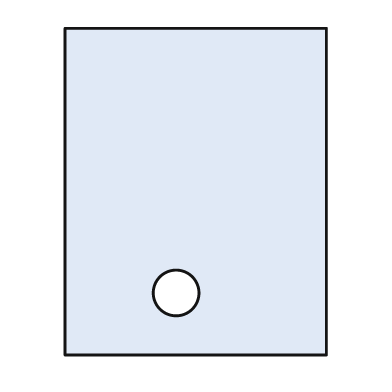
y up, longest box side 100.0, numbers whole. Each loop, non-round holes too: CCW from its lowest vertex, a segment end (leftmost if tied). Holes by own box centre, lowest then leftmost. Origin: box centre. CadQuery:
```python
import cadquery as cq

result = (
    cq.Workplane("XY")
    .moveTo(-40.0, -50.0)
    .lineTo(40.0, -50.0)
    .lineTo(40.0, 50.0)
    .lineTo(-40.0, 50.0)
    .close()
    .moveTo(-6.0, -31.0)
    .circle(7.0)
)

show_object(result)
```